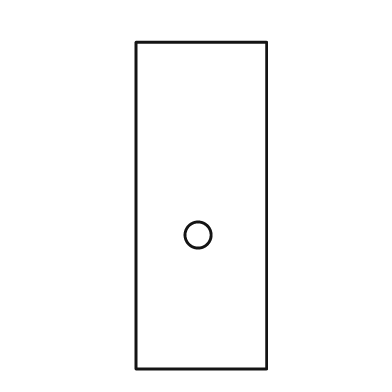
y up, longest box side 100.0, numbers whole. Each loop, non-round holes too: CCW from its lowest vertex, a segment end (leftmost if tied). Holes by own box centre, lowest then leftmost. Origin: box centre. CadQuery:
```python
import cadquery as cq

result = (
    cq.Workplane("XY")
    .moveTo(-20.0, -50.0)
    .lineTo(20.0, -50.0)
    .lineTo(20.0, 50.0)
    .lineTo(-20.0, 50.0)
    .close()
    .moveTo(-1.0, -9.0)
    .circle(4.0)
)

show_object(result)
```